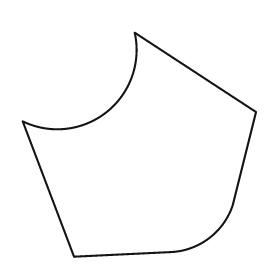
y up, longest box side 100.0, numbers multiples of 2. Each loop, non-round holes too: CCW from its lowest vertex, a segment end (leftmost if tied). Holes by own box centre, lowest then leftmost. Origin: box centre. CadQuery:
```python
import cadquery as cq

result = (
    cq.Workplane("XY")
    .moveTo(-28.0, -48.0)
    .lineTo(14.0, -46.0)
    .threePointArc((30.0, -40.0), (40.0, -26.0))
    .lineTo(50.0, 14.0)
    .lineTo(-2.0, 48.0)
    .threePointArc((-14.0, 14.0), (-50.0, 10.0))
    .close()
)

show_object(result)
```